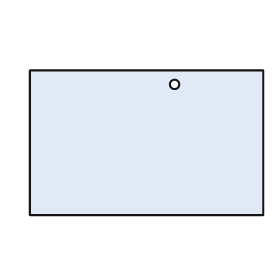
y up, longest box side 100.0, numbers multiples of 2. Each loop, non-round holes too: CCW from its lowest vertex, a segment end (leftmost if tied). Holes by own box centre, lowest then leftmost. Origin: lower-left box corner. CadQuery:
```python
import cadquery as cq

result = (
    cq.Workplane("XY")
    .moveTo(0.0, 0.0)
    .lineTo(100.0, 0.0)
    .lineTo(100.0, 62.0)
    .lineTo(0.0, 62.0)
    .close()
    .moveTo(62.0, 56.0)
    .circle(2.0)
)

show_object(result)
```